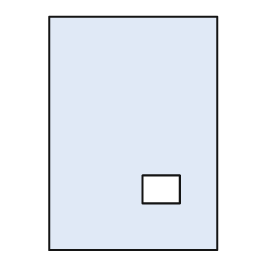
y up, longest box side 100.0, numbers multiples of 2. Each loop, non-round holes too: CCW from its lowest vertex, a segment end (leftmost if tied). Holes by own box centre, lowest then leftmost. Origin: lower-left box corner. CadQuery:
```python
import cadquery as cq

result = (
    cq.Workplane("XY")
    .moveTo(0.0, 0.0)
    .lineTo(72.0, 0.0)
    .lineTo(72.0, 100.0)
    .lineTo(0.0, 100.0)
    .close()
    .moveTo(40.0, 20.0)
    .lineTo(56.0, 20.0)
    .lineTo(56.0, 32.0)
    .lineTo(40.0, 32.0)
    .close()
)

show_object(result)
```